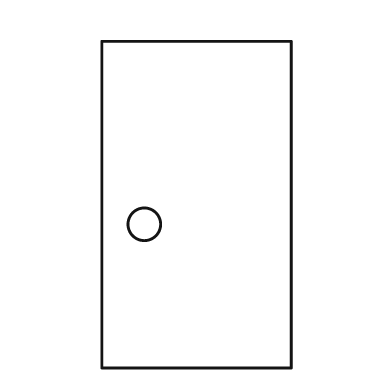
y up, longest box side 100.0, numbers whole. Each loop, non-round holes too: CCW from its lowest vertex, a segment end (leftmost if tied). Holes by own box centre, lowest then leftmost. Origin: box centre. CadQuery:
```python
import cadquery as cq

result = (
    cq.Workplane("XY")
    .moveTo(-29.0, -50.0)
    .lineTo(29.0, -50.0)
    .lineTo(29.0, 50.0)
    .lineTo(-29.0, 50.0)
    .close()
    .moveTo(-16.0, -6.0)
    .circle(5.0)
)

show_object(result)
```